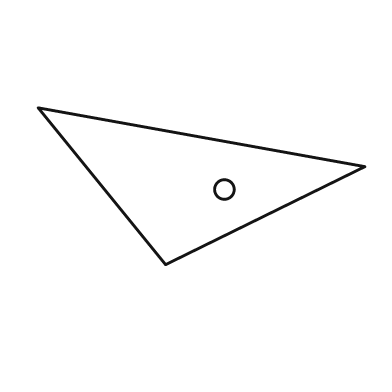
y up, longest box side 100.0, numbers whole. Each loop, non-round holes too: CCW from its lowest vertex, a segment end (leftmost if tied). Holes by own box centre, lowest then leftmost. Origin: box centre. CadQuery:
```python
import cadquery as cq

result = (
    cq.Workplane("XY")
    .moveTo(-11.0, -24.0)
    .lineTo(50.0, 6.0)
    .lineTo(-50.0, 24.0)
    .close()
    .moveTo(7.0, -1.0)
    .circle(3.0)
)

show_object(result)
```